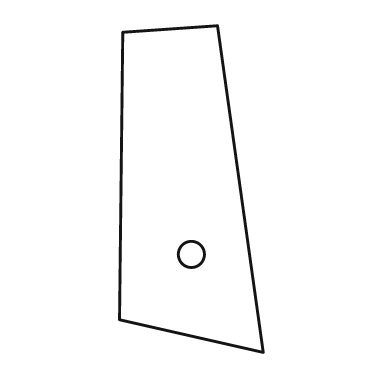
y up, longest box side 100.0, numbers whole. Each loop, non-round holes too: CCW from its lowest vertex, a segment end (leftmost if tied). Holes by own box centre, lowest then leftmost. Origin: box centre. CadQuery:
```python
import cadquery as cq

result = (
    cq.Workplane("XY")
    .moveTo(22.0, -50.0)
    .lineTo(8.0, 50.0)
    .lineTo(-21.0, 48.0)
    .lineTo(-22.0, -40.0)
    .close()
    .moveTo(0.0, -20.0)
    .circle(4.0)
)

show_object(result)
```